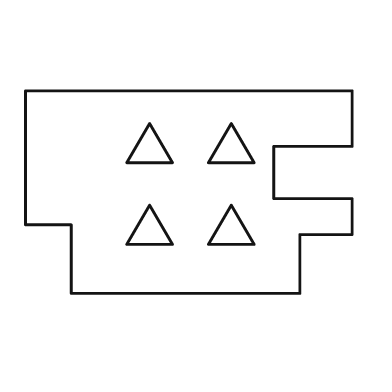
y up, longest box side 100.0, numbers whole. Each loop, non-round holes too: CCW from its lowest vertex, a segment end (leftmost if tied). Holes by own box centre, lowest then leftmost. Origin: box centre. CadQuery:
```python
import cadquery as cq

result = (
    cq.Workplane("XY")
    .moveTo(-36.0, -31.0)
    .lineTo(34.0, -31.0)
    .lineTo(34.0, -13.0)
    .lineTo(50.0, -13.0)
    .lineTo(50.0, -2.0)
    .lineTo(26.0, -2.0)
    .lineTo(26.0, 14.0)
    .lineTo(50.0, 14.0)
    .lineTo(50.0, 31.0)
    .lineTo(-50.0, 31.0)
    .lineTo(-50.0, -10.0)
    .lineTo(-36.0, -10.0)
    .close()
    .moveTo(-19.0, -16.0)
    .lineTo(-5.0, -16.0)
    .lineTo(-12.0, -4.0)
    .close()
    .moveTo(6.0, -16.0)
    .lineTo(20.0, -16.0)
    .lineTo(13.0, -4.0)
    .close()
    .moveTo(-19.0, 9.0)
    .lineTo(-5.0, 9.0)
    .lineTo(-12.0, 21.0)
    .close()
    .moveTo(6.0, 9.0)
    .lineTo(20.0, 9.0)
    .lineTo(13.0, 21.0)
    .close()
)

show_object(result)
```